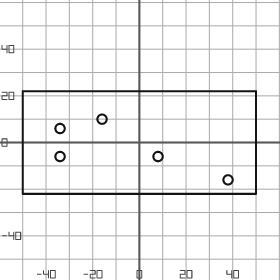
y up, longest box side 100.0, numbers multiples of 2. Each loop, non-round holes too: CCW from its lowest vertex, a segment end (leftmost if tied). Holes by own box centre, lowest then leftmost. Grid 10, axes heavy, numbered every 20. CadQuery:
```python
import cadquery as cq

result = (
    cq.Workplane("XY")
    .moveTo(-50.0, -22.0)
    .lineTo(50.0, -22.0)
    .lineTo(50.0, 22.0)
    .lineTo(-50.0, 22.0)
    .close()
    .moveTo(38.0, -16.0)
    .circle(2.0)
    .moveTo(-34.0, -6.0)
    .circle(2.0)
    .moveTo(8.0, -6.0)
    .circle(2.0)
    .moveTo(-34.0, 6.0)
    .circle(2.0)
    .moveTo(-16.0, 10.0)
    .circle(2.0)
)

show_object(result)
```